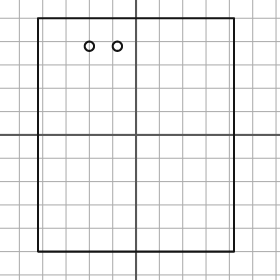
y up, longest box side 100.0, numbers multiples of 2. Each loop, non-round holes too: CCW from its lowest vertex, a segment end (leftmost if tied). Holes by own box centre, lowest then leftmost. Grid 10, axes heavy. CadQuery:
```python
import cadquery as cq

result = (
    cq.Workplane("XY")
    .moveTo(-42.0, -50.0)
    .lineTo(42.0, -50.0)
    .lineTo(42.0, 50.0)
    .lineTo(-42.0, 50.0)
    .close()
    .moveTo(-20.0, 38.0)
    .circle(2.0)
    .moveTo(-8.0, 38.0)
    .circle(2.0)
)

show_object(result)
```